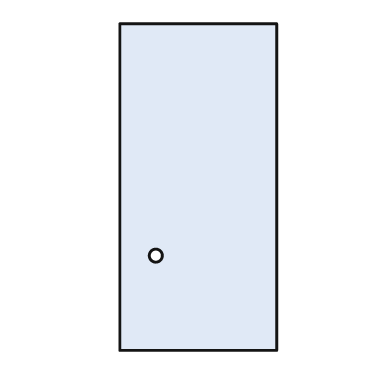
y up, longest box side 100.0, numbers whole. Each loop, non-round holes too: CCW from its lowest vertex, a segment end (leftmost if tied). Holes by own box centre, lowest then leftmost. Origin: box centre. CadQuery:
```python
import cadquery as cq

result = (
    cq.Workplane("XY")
    .moveTo(-24.0, -50.0)
    .lineTo(24.0, -50.0)
    .lineTo(24.0, 50.0)
    .lineTo(-24.0, 50.0)
    .close()
    .moveTo(-13.0, -21.0)
    .circle(2.0)
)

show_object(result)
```